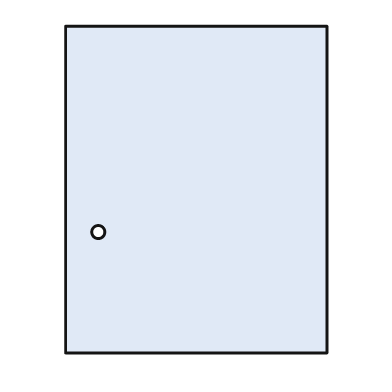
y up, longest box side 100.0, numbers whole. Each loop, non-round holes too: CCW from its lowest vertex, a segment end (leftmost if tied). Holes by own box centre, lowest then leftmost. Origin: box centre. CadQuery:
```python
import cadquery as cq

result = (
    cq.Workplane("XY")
    .moveTo(-40.0, -50.0)
    .lineTo(40.0, -50.0)
    .lineTo(40.0, 50.0)
    .lineTo(-40.0, 50.0)
    .close()
    .moveTo(-30.0, -13.0)
    .circle(2.0)
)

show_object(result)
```